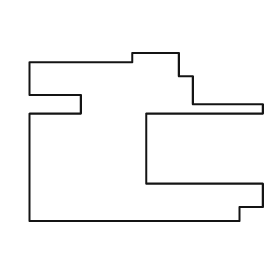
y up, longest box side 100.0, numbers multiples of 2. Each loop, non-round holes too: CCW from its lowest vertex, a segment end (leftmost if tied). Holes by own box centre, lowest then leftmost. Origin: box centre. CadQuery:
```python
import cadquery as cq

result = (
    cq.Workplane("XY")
    .moveTo(-50.0, -36.0)
    .lineTo(40.0, -36.0)
    .lineTo(40.0, -30.0)
    .lineTo(50.0, -30.0)
    .lineTo(50.0, -20.0)
    .lineTo(0.0, -20.0)
    .lineTo(0.0, 10.0)
    .lineTo(50.0, 10.0)
    .lineTo(50.0, 14.0)
    .lineTo(20.0, 14.0)
    .lineTo(20.0, 26.0)
    .lineTo(14.0, 26.0)
    .lineTo(14.0, 36.0)
    .lineTo(-6.0, 36.0)
    .lineTo(-6.0, 32.0)
    .lineTo(-50.0, 32.0)
    .lineTo(-50.0, 18.0)
    .lineTo(-28.0, 18.0)
    .lineTo(-28.0, 10.0)
    .lineTo(-50.0, 10.0)
    .close()
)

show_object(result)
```